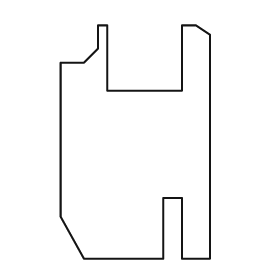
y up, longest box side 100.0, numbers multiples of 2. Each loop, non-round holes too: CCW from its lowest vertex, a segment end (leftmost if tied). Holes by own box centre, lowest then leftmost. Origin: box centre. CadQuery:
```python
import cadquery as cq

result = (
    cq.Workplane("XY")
    .moveTo(-22.0, -50.0)
    .lineTo(12.0, -50.0)
    .lineTo(12.0, -24.0)
    .lineTo(20.0, -24.0)
    .lineTo(20.0, -50.0)
    .lineTo(32.0, -50.0)
    .lineTo(32.0, 46.0)
    .lineTo(26.0, 50.0)
    .lineTo(20.0, 50.0)
    .lineTo(20.0, 22.0)
    .lineTo(-12.0, 22.0)
    .lineTo(-12.0, 50.0)
    .lineTo(-16.0, 50.0)
    .lineTo(-16.0, 40.0)
    .lineTo(-22.0, 34.0)
    .lineTo(-32.0, 34.0)
    .lineTo(-32.0, -32.0)
    .close()
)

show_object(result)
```